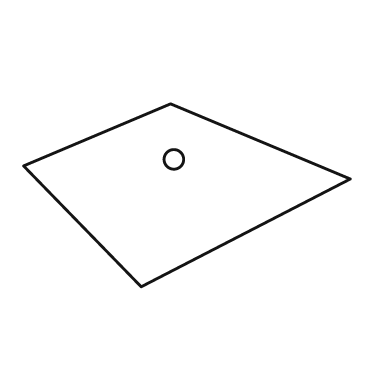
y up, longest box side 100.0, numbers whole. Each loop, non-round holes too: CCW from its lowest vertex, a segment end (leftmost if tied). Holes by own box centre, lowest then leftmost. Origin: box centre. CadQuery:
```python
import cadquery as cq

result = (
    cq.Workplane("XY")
    .moveTo(-14.0, -28.0)
    .lineTo(50.0, 5.0)
    .lineTo(-5.0, 28.0)
    .lineTo(-50.0, 9.0)
    .close()
    .moveTo(-4.0, 11.0)
    .circle(3.0)
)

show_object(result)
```